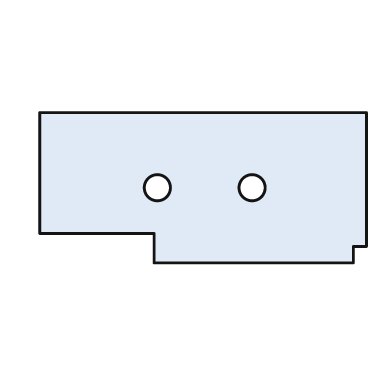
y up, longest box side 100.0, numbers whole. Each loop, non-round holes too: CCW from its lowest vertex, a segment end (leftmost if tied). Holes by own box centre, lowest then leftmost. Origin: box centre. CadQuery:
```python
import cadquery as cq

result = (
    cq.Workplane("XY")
    .moveTo(-15.0, -23.0)
    .lineTo(46.0, -23.0)
    .lineTo(46.0, -18.0)
    .lineTo(50.0, -18.0)
    .lineTo(50.0, 23.0)
    .lineTo(-50.0, 23.0)
    .lineTo(-50.0, -14.0)
    .lineTo(-15.0, -14.0)
    .close()
    .moveTo(-14.0, 0.0)
    .circle(4.0)
    .moveTo(15.0, 0.0)
    .circle(4.0)
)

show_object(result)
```